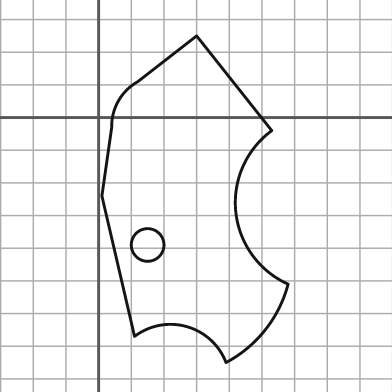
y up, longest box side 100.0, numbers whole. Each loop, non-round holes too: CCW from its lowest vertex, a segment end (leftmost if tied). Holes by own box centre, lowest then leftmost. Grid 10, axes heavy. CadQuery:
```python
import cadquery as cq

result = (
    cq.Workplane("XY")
    .moveTo(39.0, -75.0)
    .threePointArc((51.0, -65.0), (58.0, -51.0))
    .threePointArc((42.0, -29.0), (53.0, -4.0))
    .lineTo(30.0, 25.0)
    .lineTo(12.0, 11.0)
    .threePointArc((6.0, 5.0), (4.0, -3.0))
    .lineTo(1.0, -24.0)
    .lineTo(11.0, -67.0)
    .threePointArc((27.0, -64.0), (39.0, -75.0))
    .close()
    .moveTo(15.0, -39.0)
    .circle(5.0)
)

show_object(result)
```